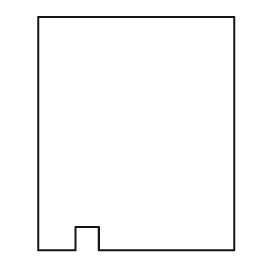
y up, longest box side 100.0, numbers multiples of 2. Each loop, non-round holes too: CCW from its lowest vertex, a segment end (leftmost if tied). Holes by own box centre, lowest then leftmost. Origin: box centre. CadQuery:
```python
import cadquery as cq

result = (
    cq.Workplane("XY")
    .moveTo(-42.0, -50.0)
    .lineTo(-26.0, -50.0)
    .lineTo(-26.0, -40.0)
    .lineTo(-16.0, -40.0)
    .lineTo(-16.0, -50.0)
    .lineTo(42.0, -50.0)
    .lineTo(42.0, 50.0)
    .lineTo(-42.0, 50.0)
    .close()
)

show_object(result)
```